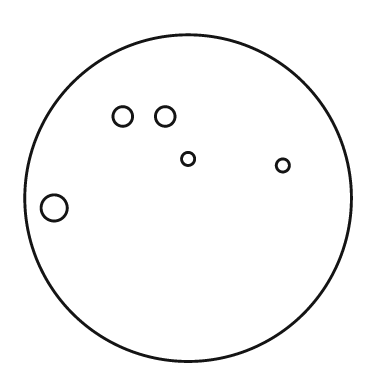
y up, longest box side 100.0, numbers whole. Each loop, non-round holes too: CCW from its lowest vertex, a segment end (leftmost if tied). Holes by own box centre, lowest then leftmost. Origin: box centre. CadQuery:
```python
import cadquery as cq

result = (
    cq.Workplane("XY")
    .moveTo(0.0, 0.0)
    .circle(50.0)
    .moveTo(-41.0, -3.0)
    .circle(4.0)
    .moveTo(29.0, 10.0)
    .circle(2.0)
    .moveTo(0.0, 12.0)
    .circle(2.0)
    .moveTo(-20.0, 25.0)
    .circle(3.0)
    .moveTo(-7.0, 25.0)
    .circle(3.0)
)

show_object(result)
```